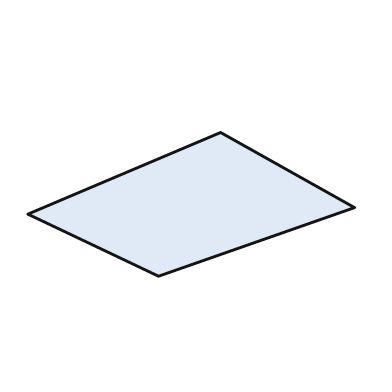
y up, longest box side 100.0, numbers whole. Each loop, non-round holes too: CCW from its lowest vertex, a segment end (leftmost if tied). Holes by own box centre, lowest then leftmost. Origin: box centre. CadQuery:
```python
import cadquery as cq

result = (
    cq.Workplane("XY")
    .moveTo(-10.0, -22.0)
    .lineTo(50.0, -1.0)
    .lineTo(9.0, 22.0)
    .lineTo(-50.0, -3.0)
    .close()
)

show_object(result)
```